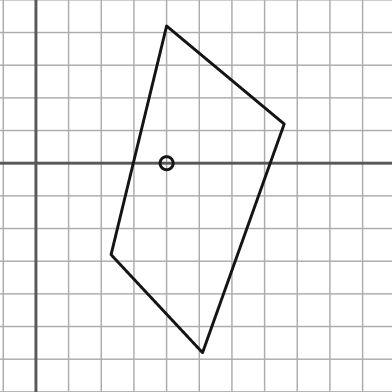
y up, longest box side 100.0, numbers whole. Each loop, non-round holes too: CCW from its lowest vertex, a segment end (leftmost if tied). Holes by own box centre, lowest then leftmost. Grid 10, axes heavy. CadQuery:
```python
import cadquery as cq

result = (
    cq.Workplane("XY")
    .moveTo(51.0, -58.0)
    .lineTo(76.0, 12.0)
    .lineTo(40.0, 42.0)
    .lineTo(23.0, -28.0)
    .close()
    .moveTo(40.0, 0.0)
    .circle(2.0)
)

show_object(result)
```